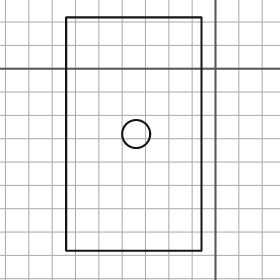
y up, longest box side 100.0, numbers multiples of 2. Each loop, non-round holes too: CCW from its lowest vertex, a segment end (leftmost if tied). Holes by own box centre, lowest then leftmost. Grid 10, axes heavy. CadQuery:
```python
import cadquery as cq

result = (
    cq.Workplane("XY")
    .moveTo(-64.0, -78.0)
    .lineTo(-6.0, -78.0)
    .lineTo(-6.0, 22.0)
    .lineTo(-64.0, 22.0)
    .close()
    .moveTo(-34.0, -28.0)
    .circle(6.0)
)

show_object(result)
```